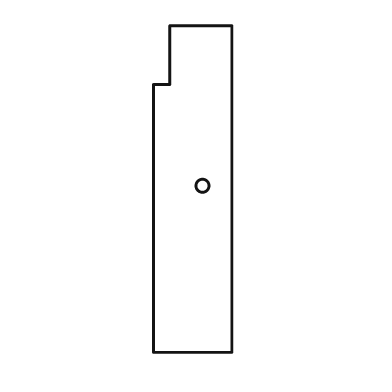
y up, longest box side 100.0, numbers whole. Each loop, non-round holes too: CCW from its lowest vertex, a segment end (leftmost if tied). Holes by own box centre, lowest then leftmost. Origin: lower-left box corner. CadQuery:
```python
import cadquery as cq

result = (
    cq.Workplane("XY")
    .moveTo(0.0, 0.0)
    .lineTo(24.0, 0.0)
    .lineTo(24.0, 100.0)
    .lineTo(5.0, 100.0)
    .lineTo(5.0, 82.0)
    .lineTo(0.0, 82.0)
    .close()
    .moveTo(15.0, 51.0)
    .circle(2.0)
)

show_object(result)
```